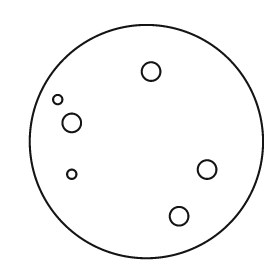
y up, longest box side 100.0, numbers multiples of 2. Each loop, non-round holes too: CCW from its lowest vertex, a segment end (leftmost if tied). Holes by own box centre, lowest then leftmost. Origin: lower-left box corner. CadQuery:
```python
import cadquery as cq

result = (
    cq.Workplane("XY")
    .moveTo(50.0, 50.0)
    .circle(50.0)
    .moveTo(64.0, 18.0)
    .circle(4.0)
    .moveTo(18.0, 36.0)
    .circle(2.0)
    .moveTo(76.0, 38.0)
    .circle(4.0)
    .moveTo(18.0, 58.0)
    .circle(4.0)
    .moveTo(12.0, 68.0)
    .circle(2.0)
    .moveTo(52.0, 80.0)
    .circle(4.0)
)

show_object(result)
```